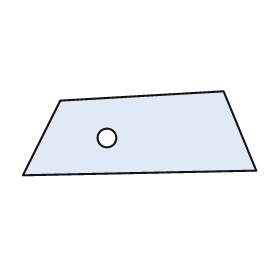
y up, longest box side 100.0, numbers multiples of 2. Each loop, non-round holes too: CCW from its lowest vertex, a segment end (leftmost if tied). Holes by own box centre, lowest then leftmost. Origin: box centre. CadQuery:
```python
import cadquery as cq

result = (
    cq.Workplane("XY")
    .moveTo(-50.0, -18.0)
    .lineTo(50.0, -16.0)
    .lineTo(36.0, 18.0)
    .lineTo(-34.0, 14.0)
    .close()
    .moveTo(-14.0, -2.0)
    .circle(4.0)
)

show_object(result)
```